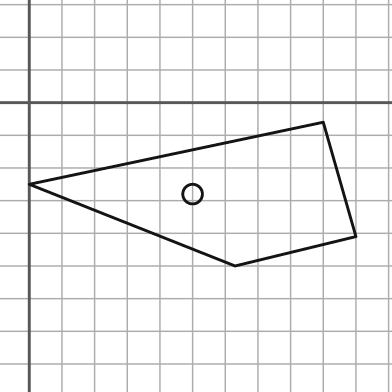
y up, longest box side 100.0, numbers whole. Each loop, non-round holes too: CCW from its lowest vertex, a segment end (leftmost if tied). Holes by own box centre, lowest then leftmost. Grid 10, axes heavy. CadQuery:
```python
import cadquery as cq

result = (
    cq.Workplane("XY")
    .moveTo(63.0, -50.0)
    .lineTo(100.0, -41.0)
    .lineTo(90.0, -6.0)
    .lineTo(0.0, -25.0)
    .close()
    .moveTo(50.0, -28.0)
    .circle(3.0)
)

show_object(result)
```